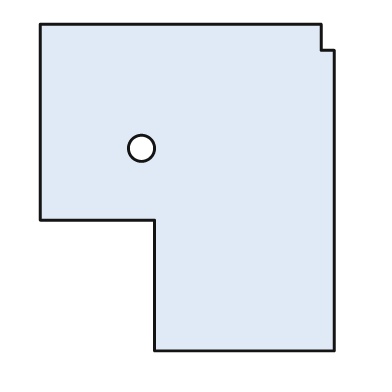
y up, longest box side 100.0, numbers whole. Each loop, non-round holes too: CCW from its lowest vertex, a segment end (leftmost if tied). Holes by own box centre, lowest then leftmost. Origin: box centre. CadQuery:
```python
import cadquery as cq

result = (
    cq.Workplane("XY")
    .moveTo(-10.0, -50.0)
    .lineTo(45.0, -50.0)
    .lineTo(45.0, 42.0)
    .lineTo(41.0, 42.0)
    .lineTo(41.0, 50.0)
    .lineTo(-45.0, 50.0)
    .lineTo(-45.0, -10.0)
    .lineTo(-10.0, -10.0)
    .close()
    .moveTo(-14.0, 12.0)
    .circle(4.0)
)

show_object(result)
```